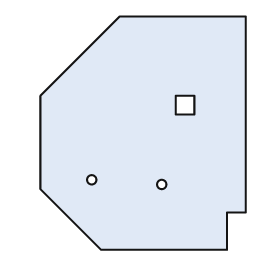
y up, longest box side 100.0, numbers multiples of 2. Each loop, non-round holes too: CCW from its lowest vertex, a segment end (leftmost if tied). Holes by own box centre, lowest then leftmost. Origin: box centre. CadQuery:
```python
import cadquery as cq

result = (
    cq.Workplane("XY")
    .moveTo(-18.0, -50.0)
    .lineTo(36.0, -50.0)
    .lineTo(36.0, -34.0)
    .lineTo(44.0, -34.0)
    .lineTo(44.0, 50.0)
    .lineTo(-10.0, 50.0)
    .lineTo(-44.0, 16.0)
    .lineTo(-44.0, -24.0)
    .close()
    .moveTo(8.0, -22.0)
    .circle(2.0)
    .moveTo(-22.0, -20.0)
    .circle(2.0)
    .moveTo(14.0, 8.0)
    .lineTo(22.0, 8.0)
    .lineTo(22.0, 16.0)
    .lineTo(14.0, 16.0)
    .close()
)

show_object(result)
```